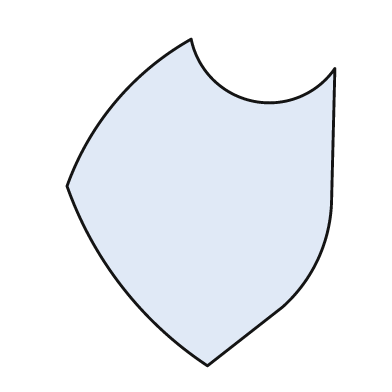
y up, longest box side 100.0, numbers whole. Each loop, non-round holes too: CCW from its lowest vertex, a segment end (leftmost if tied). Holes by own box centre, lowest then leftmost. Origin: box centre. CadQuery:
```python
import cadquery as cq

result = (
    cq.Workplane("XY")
    .moveTo(2.0, -50.0)
    .lineTo(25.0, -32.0)
    .threePointArc((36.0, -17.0), (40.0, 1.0))
    .lineTo(41.0, 41.0)
    .threePointArc((16.0, 31.0), (-3.0, 50.0))
    .threePointArc((-26.0, 31.0), (-41.0, 5.0))
    .threePointArc((-24.0, -26.0), (2.0, -50.0))
    .close()
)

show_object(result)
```